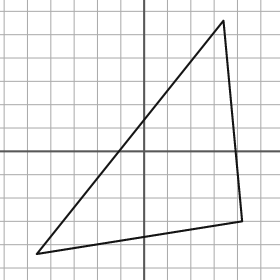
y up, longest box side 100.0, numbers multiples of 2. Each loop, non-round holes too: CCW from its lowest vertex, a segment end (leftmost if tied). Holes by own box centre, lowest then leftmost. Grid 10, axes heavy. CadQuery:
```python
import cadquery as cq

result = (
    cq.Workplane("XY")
    .moveTo(-46.0, -44.0)
    .lineTo(42.0, -30.0)
    .lineTo(34.0, 56.0)
    .close()
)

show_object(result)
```